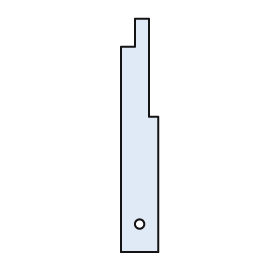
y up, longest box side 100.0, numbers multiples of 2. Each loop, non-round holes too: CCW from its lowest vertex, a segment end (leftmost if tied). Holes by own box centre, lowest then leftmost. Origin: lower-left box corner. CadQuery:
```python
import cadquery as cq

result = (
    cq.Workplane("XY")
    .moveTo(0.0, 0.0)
    .lineTo(16.0, 0.0)
    .lineTo(16.0, 58.0)
    .lineTo(12.0, 58.0)
    .lineTo(12.0, 100.0)
    .lineTo(6.0, 100.0)
    .lineTo(6.0, 88.0)
    .lineTo(0.0, 88.0)
    .close()
    .moveTo(8.0, 12.0)
    .circle(2.0)
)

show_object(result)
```